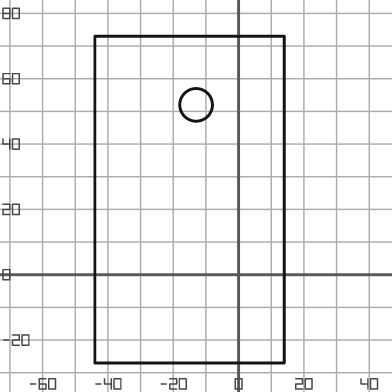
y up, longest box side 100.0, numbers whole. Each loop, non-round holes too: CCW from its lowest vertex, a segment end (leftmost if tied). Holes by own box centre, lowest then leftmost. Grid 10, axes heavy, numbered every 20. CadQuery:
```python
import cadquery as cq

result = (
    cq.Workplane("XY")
    .moveTo(-44.0, -27.0)
    .lineTo(14.0, -27.0)
    .lineTo(14.0, 73.0)
    .lineTo(-44.0, 73.0)
    .close()
    .moveTo(-13.0, 52.0)
    .circle(5.0)
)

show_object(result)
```